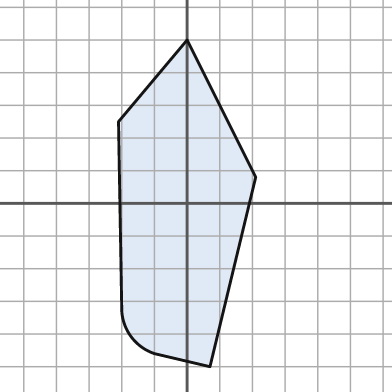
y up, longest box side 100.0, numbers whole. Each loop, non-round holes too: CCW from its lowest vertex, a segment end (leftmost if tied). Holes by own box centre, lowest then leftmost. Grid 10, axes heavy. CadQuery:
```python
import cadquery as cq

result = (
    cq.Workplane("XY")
    .moveTo(7.0, -50.0)
    .lineTo(21.0, 8.0)
    .lineTo(0.0, 50.0)
    .lineTo(-21.0, 25.0)
    .lineTo(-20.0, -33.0)
    .threePointArc((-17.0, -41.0), (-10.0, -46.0))
    .close()
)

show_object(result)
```